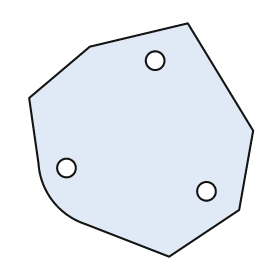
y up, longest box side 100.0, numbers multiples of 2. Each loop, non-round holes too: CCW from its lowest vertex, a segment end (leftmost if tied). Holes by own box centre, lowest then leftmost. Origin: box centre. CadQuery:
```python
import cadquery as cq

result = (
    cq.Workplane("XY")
    .moveTo(12.0, -50.0)
    .lineTo(42.0, -30.0)
    .lineTo(48.0, 4.0)
    .lineTo(20.0, 50.0)
    .lineTo(-22.0, 40.0)
    .lineTo(-48.0, 18.0)
    .lineTo(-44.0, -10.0)
    .threePointArc((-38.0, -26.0), (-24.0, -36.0))
    .close()
    .moveTo(28.0, -22.0)
    .circle(4.0)
    .moveTo(-32.0, -12.0)
    .circle(4.0)
    .moveTo(6.0, 34.0)
    .circle(4.0)
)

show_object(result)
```